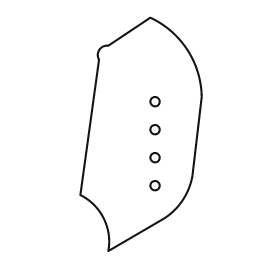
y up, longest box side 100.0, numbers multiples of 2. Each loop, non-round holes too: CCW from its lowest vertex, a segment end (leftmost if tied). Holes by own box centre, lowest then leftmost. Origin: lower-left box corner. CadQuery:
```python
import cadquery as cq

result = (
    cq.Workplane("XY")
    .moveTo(12.0, 0.0)
    .lineTo(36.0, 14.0)
    .threePointArc((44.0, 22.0), (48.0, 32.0))
    .lineTo(52.0, 66.0)
    .threePointArc((46.0, 86.0), (30.0, 100.0))
    .lineTo(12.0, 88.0)
    .threePointArc((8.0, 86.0), (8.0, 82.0))
    .lineTo(0.0, 24.0)
    .threePointArc((10.0, 14.0), (12.0, 0.0))
    .close()
    .moveTo(32.0, 28.0)
    .circle(2.0)
    .moveTo(32.0, 40.0)
    .circle(2.0)
    .moveTo(32.0, 52.0)
    .circle(2.0)
    .moveTo(32.0, 64.0)
    .circle(2.0)
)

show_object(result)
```